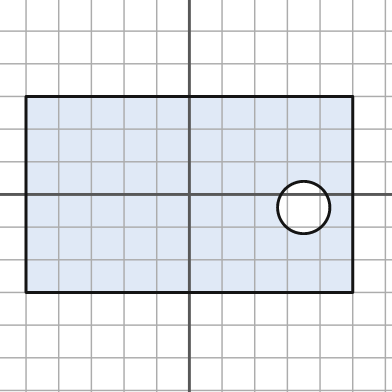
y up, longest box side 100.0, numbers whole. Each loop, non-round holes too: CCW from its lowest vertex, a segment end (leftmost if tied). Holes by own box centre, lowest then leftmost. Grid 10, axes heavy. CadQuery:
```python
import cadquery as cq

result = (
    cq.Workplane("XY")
    .moveTo(-50.0, -30.0)
    .lineTo(50.0, -30.0)
    .lineTo(50.0, 30.0)
    .lineTo(-50.0, 30.0)
    .close()
    .moveTo(35.0, -4.0)
    .circle(8.0)
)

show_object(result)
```